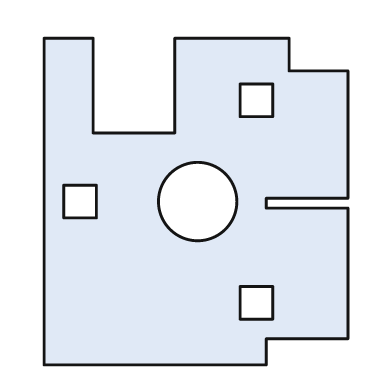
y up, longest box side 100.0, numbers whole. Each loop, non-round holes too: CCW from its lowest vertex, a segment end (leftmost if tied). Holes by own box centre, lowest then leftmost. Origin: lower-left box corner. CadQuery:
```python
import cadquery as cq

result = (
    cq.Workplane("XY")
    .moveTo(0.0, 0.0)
    .lineTo(68.0, 0.0)
    .lineTo(68.0, 8.0)
    .lineTo(93.0, 8.0)
    .lineTo(93.0, 48.0)
    .lineTo(68.0, 48.0)
    .lineTo(68.0, 51.0)
    .lineTo(93.0, 51.0)
    .lineTo(93.0, 90.0)
    .lineTo(75.0, 90.0)
    .lineTo(75.0, 100.0)
    .lineTo(40.0, 100.0)
    .lineTo(40.0, 71.0)
    .lineTo(15.0, 71.0)
    .lineTo(15.0, 100.0)
    .lineTo(0.0, 100.0)
    .close()
    .moveTo(60.0, 14.0)
    .lineTo(70.0, 14.0)
    .lineTo(70.0, 24.0)
    .lineTo(60.0, 24.0)
    .close()
    .moveTo(6.0, 45.0)
    .lineTo(16.0, 45.0)
    .lineTo(16.0, 55.0)
    .lineTo(6.0, 55.0)
    .close()
    .moveTo(47.0, 50.0)
    .circle(12.0)
    .moveTo(60.0, 76.0)
    .lineTo(70.0, 76.0)
    .lineTo(70.0, 86.0)
    .lineTo(60.0, 86.0)
    .close()
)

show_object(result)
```